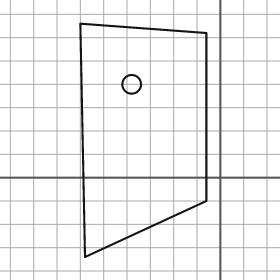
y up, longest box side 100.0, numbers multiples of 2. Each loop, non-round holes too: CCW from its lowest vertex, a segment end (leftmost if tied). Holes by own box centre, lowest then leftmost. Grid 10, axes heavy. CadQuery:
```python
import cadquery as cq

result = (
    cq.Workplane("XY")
    .moveTo(-58.0, -34.0)
    .lineTo(-6.0, -10.0)
    .lineTo(-6.0, 62.0)
    .lineTo(-60.0, 66.0)
    .close()
    .moveTo(-38.0, 40.0)
    .circle(4.0)
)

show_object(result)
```